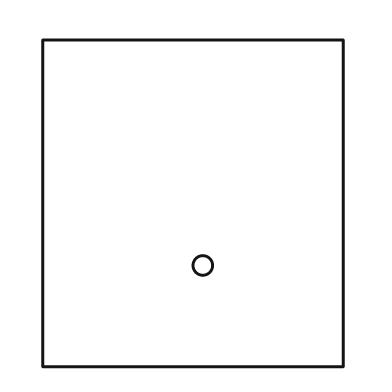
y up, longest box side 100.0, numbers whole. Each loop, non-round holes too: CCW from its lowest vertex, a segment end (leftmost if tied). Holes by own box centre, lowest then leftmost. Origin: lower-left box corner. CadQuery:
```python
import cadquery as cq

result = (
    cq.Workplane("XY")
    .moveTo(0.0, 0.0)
    .lineTo(92.0, 0.0)
    .lineTo(92.0, 100.0)
    .lineTo(0.0, 100.0)
    .close()
    .moveTo(49.0, 31.0)
    .circle(3.0)
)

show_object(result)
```